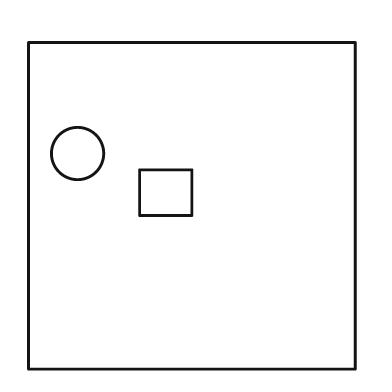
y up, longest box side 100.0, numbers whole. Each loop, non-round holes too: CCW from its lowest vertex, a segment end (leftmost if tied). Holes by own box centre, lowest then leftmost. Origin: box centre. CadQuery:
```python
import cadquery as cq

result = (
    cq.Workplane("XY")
    .moveTo(-50.0, -50.0)
    .lineTo(50.0, -50.0)
    .lineTo(50.0, 50.0)
    .lineTo(-50.0, 50.0)
    .close()
    .moveTo(-16.0, -3.0)
    .lineTo(0.0, -3.0)
    .lineTo(0.0, 11.0)
    .lineTo(-16.0, 11.0)
    .close()
    .moveTo(-35.0, 16.0)
    .circle(8.0)
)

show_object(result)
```